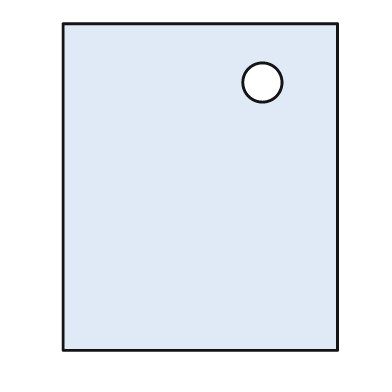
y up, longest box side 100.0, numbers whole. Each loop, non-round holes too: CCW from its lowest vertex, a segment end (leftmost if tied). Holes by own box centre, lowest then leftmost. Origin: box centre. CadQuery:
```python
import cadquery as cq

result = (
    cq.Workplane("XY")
    .moveTo(-42.0, -50.0)
    .lineTo(42.0, -50.0)
    .lineTo(42.0, 50.0)
    .lineTo(-42.0, 50.0)
    .close()
    .moveTo(19.0, 32.0)
    .circle(6.0)
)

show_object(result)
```